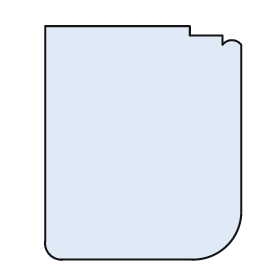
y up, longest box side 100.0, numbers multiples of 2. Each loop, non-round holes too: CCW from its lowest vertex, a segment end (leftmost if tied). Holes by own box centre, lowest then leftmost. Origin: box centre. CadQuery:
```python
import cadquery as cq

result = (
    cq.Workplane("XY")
    .moveTo(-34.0, -50.0)
    .lineTo(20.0, -50.0)
    .threePointArc((36.0, -44.0), (42.0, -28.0))
    .lineTo(42.0, 42.0)
    .threePointArc((38.0, 44.0), (34.0, 42.0))
    .lineTo(34.0, 46.0)
    .lineTo(20.0, 46.0)
    .lineTo(20.0, 50.0)
    .lineTo(-42.0, 50.0)
    .lineTo(-42.0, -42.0)
    .threePointArc((-40.0, -48.0), (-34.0, -50.0))
    .close()
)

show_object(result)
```